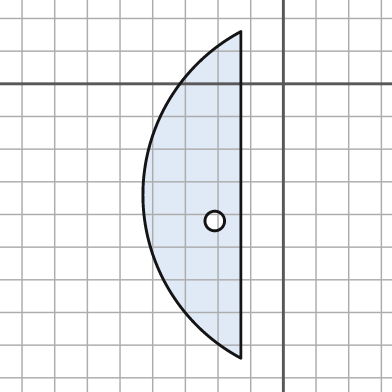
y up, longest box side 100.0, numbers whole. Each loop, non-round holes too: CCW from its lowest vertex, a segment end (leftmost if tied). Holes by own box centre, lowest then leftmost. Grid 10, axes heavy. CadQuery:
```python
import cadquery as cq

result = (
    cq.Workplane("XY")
    .moveTo(-13.0, -84.0)
    .lineTo(-13.0, 16.0)
    .threePointArc((-43.0, -34.0), (-13.0, -84.0))
    .close()
    .moveTo(-21.0, -42.0)
    .circle(3.0)
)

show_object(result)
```